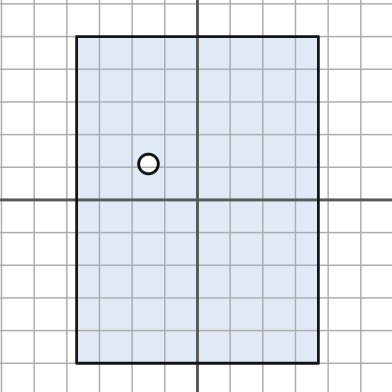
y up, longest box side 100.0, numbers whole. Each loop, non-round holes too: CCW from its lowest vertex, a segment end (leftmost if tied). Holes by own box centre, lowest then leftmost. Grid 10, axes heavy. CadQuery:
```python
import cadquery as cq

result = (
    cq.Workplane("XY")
    .moveTo(-37.0, -50.0)
    .lineTo(37.0, -50.0)
    .lineTo(37.0, 50.0)
    .lineTo(-37.0, 50.0)
    .close()
    .moveTo(-15.0, 11.0)
    .circle(3.0)
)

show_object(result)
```